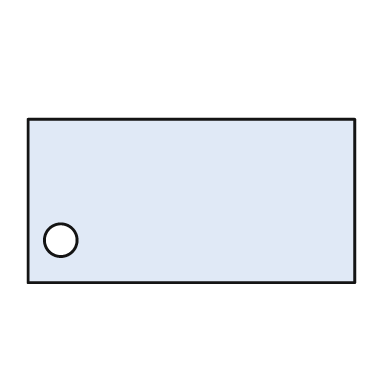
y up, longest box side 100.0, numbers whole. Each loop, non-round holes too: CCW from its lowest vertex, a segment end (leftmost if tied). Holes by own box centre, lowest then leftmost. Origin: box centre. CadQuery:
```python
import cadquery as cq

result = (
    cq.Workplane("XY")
    .moveTo(-50.0, -25.0)
    .lineTo(50.0, -25.0)
    .lineTo(50.0, 25.0)
    .lineTo(-50.0, 25.0)
    .close()
    .moveTo(-40.0, -12.0)
    .circle(5.0)
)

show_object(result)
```